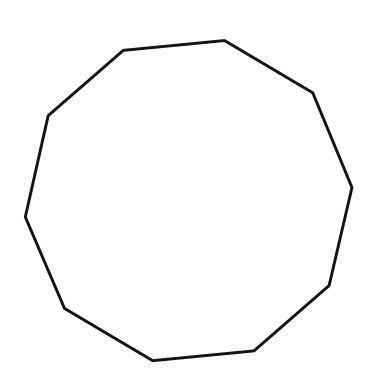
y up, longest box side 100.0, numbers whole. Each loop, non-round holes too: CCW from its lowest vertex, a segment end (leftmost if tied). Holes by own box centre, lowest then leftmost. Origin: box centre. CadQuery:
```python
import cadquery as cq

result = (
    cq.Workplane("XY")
    .moveTo(-11.0, -49.0)
    .lineTo(20.0, -46.0)
    .lineTo(43.0, -26.0)
    .lineTo(50.0, 4.0)
    .lineTo(38.0, 33.0)
    .lineTo(11.0, 49.0)
    .lineTo(-20.0, 46.0)
    .lineTo(-43.0, 26.0)
    .lineTo(-50.0, -5.0)
    .lineTo(-38.0, -33.0)
    .close()
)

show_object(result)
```